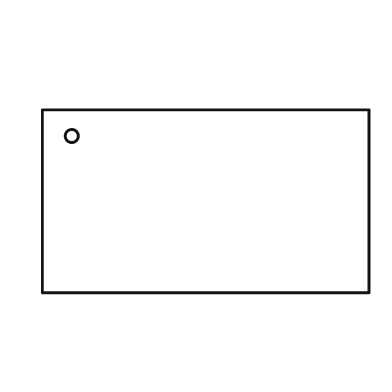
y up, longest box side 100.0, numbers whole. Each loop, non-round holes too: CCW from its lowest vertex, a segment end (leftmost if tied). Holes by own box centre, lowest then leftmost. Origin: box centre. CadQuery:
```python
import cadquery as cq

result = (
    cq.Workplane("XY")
    .moveTo(-50.0, -28.0)
    .lineTo(50.0, -28.0)
    .lineTo(50.0, 28.0)
    .lineTo(-50.0, 28.0)
    .close()
    .moveTo(-41.0, 20.0)
    .circle(2.0)
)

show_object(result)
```